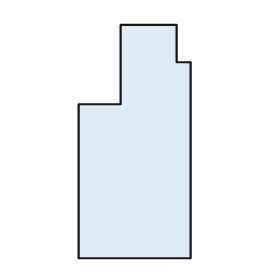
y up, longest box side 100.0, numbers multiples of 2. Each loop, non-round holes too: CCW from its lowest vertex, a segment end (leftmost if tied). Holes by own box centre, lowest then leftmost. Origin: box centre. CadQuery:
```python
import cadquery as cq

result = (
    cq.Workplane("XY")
    .moveTo(-24.0, -50.0)
    .lineTo(24.0, -50.0)
    .lineTo(24.0, 34.0)
    .lineTo(18.0, 34.0)
    .lineTo(18.0, 50.0)
    .lineTo(-6.0, 50.0)
    .lineTo(-6.0, 16.0)
    .lineTo(-24.0, 16.0)
    .close()
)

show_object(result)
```